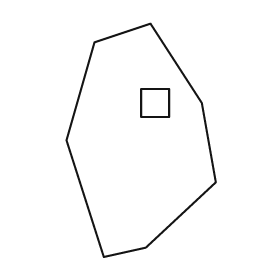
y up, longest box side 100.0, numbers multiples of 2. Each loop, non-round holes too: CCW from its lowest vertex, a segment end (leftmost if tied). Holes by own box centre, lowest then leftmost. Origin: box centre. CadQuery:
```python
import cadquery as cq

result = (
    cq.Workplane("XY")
    .moveTo(-16.0, -50.0)
    .lineTo(2.0, -46.0)
    .lineTo(32.0, -18.0)
    .lineTo(26.0, 16.0)
    .lineTo(4.0, 50.0)
    .lineTo(-20.0, 42.0)
    .lineTo(-32.0, 0.0)
    .close()
    .moveTo(0.0, 10.0)
    .lineTo(12.0, 10.0)
    .lineTo(12.0, 22.0)
    .lineTo(0.0, 22.0)
    .close()
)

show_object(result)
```